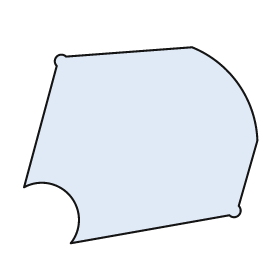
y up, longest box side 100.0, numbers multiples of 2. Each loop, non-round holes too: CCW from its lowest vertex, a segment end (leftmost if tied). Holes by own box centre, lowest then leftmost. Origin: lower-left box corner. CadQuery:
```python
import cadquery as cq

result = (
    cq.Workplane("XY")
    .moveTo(20.0, 0.0)
    .lineTo(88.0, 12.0)
    .threePointArc((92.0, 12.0), (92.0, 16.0))
    .lineTo(100.0, 44.0)
    .threePointArc((92.0, 68.0), (72.0, 84.0))
    .lineTo(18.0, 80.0)
    .threePointArc((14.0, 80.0), (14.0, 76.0))
    .lineTo(0.0, 24.0)
    .threePointArc((20.0, 20.0), (20.0, 0.0))
    .close()
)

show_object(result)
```